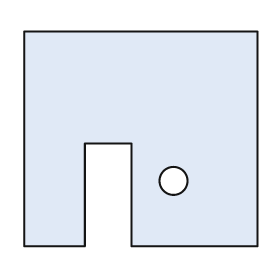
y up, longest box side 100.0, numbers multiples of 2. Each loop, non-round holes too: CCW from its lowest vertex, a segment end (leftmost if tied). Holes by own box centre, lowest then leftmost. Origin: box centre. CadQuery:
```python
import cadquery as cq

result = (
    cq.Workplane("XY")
    .moveTo(-50.0, -46.0)
    .lineTo(-24.0, -46.0)
    .lineTo(-24.0, -2.0)
    .lineTo(-4.0, -2.0)
    .lineTo(-4.0, -46.0)
    .lineTo(50.0, -46.0)
    .lineTo(50.0, 46.0)
    .lineTo(-50.0, 46.0)
    .close()
    .moveTo(14.0, -18.0)
    .circle(6.0)
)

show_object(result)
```